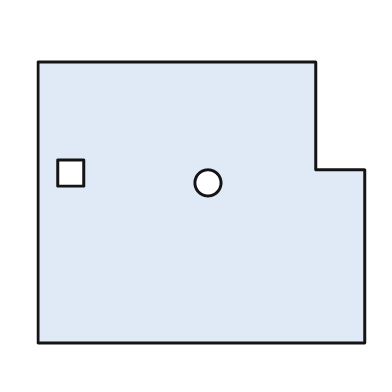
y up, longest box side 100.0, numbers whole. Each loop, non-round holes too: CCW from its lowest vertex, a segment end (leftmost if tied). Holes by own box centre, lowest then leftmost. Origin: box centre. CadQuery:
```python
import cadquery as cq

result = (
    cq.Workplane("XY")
    .moveTo(-50.0, -43.0)
    .lineTo(50.0, -43.0)
    .lineTo(50.0, 10.0)
    .lineTo(35.0, 10.0)
    .lineTo(35.0, 43.0)
    .lineTo(-50.0, 43.0)
    .close()
    .moveTo(2.0, 6.0)
    .circle(4.0)
    .moveTo(-44.0, 5.0)
    .lineTo(-36.0, 5.0)
    .lineTo(-36.0, 13.0)
    .lineTo(-44.0, 13.0)
    .close()
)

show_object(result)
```